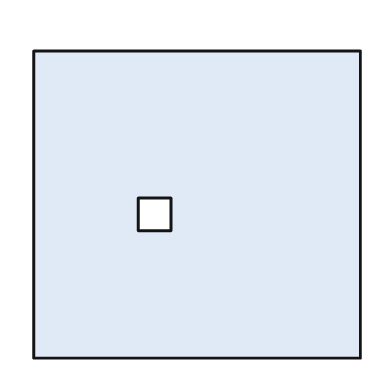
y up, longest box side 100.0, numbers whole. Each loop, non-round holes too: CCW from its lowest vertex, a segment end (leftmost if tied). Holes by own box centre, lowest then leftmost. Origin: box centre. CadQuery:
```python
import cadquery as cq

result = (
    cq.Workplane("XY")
    .moveTo(-50.0, -47.0)
    .lineTo(50.0, -47.0)
    .lineTo(50.0, 47.0)
    .lineTo(-50.0, 47.0)
    .close()
    .moveTo(-18.0, -8.0)
    .lineTo(-8.0, -8.0)
    .lineTo(-8.0, 2.0)
    .lineTo(-18.0, 2.0)
    .close()
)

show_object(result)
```